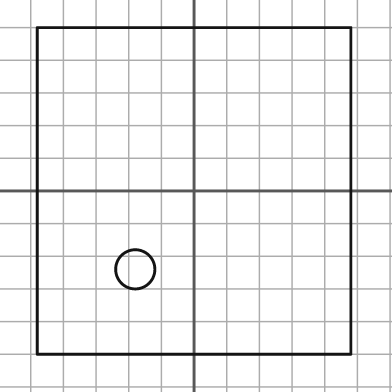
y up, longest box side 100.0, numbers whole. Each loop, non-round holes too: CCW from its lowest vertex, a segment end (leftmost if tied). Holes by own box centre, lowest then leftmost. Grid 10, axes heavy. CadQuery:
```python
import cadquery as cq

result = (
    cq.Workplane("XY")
    .moveTo(-48.0, -50.0)
    .lineTo(48.0, -50.0)
    .lineTo(48.0, 50.0)
    .lineTo(-48.0, 50.0)
    .close()
    .moveTo(-18.0, -24.0)
    .circle(6.0)
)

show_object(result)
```